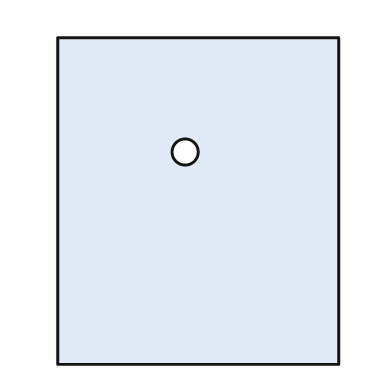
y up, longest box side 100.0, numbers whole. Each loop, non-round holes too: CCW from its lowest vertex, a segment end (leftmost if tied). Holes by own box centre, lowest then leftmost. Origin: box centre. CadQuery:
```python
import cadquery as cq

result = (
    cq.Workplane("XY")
    .moveTo(-43.0, -50.0)
    .lineTo(43.0, -50.0)
    .lineTo(43.0, 50.0)
    .lineTo(-43.0, 50.0)
    .close()
    .moveTo(-4.0, 15.0)
    .circle(4.0)
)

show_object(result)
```